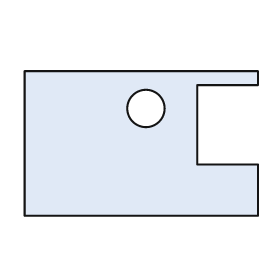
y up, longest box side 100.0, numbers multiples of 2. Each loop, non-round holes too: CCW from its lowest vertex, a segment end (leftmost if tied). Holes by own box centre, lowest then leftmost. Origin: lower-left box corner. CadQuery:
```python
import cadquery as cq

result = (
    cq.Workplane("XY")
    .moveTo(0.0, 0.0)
    .lineTo(100.0, 0.0)
    .lineTo(100.0, 22.0)
    .lineTo(74.0, 22.0)
    .lineTo(74.0, 56.0)
    .lineTo(100.0, 56.0)
    .lineTo(100.0, 62.0)
    .lineTo(0.0, 62.0)
    .close()
    .moveTo(52.0, 46.0)
    .circle(8.0)
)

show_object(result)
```